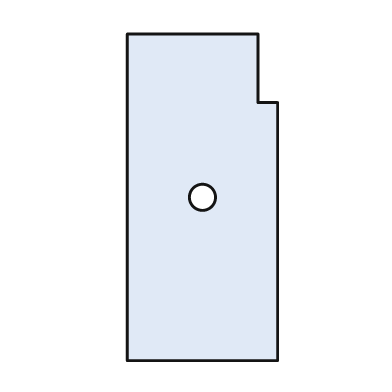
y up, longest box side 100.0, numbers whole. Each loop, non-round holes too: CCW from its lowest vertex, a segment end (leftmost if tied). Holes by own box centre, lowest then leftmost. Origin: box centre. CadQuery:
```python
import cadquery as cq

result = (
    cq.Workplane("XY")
    .moveTo(-23.0, -50.0)
    .lineTo(23.0, -50.0)
    .lineTo(23.0, 29.0)
    .lineTo(17.0, 29.0)
    .lineTo(17.0, 50.0)
    .lineTo(-23.0, 50.0)
    .close()
    .moveTo(0.0, 0.0)
    .circle(4.0)
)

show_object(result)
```